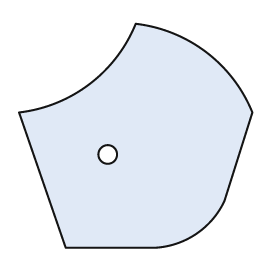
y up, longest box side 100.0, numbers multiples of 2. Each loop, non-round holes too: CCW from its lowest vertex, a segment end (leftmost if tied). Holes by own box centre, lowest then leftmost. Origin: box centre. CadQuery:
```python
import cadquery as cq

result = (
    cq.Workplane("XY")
    .moveTo(-30.0, -48.0)
    .lineTo(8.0, -48.0)
    .threePointArc((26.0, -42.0), (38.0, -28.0))
    .lineTo(50.0, 10.0)
    .threePointArc((30.0, 36.0), (0.0, 48.0))
    .threePointArc((-20.0, 22.0), (-50.0, 10.0))
    .close()
    .moveTo(-12.0, -8.0)
    .circle(4.0)
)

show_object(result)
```